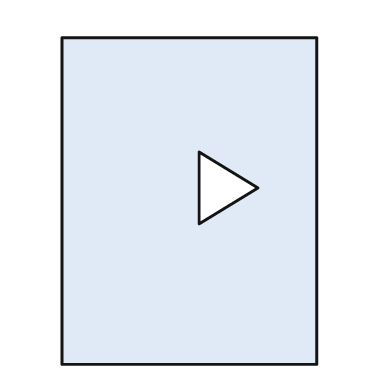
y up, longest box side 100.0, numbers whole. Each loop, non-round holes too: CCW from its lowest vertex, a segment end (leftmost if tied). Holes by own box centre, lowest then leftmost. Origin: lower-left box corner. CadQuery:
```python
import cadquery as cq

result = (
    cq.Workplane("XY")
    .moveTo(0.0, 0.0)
    .lineTo(78.0, 0.0)
    .lineTo(78.0, 100.0)
    .lineTo(0.0, 100.0)
    .close()
    .moveTo(42.0, 43.0)
    .lineTo(60.0, 54.0)
    .lineTo(42.0, 65.0)
    .close()
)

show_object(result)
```